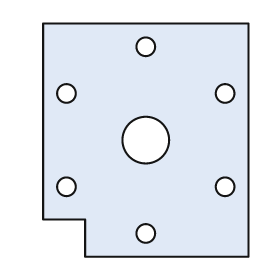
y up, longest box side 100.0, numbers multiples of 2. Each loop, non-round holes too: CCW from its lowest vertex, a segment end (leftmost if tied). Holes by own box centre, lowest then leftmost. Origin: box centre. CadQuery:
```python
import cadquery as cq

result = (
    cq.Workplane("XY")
    .moveTo(-26.0, -50.0)
    .lineTo(44.0, -50.0)
    .lineTo(44.0, 50.0)
    .lineTo(-44.0, 50.0)
    .lineTo(-44.0, -34.0)
    .lineTo(-26.0, -34.0)
    .close()
    .moveTo(0.0, -40.0)
    .circle(4.0)
    .moveTo(-34.0, -20.0)
    .circle(4.0)
    .moveTo(34.0, -20.0)
    .circle(4.0)
    .moveTo(0.0, 0.0)
    .circle(10.0)
    .moveTo(-34.0, 20.0)
    .circle(4.0)
    .moveTo(34.0, 20.0)
    .circle(4.0)
    .moveTo(0.0, 40.0)
    .circle(4.0)
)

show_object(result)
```